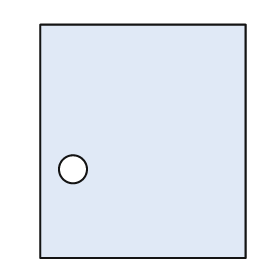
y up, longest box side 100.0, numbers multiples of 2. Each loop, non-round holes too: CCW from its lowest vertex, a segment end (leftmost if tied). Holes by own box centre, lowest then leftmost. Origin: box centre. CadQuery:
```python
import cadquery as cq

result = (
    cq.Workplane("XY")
    .moveTo(-44.0, -50.0)
    .lineTo(44.0, -50.0)
    .lineTo(44.0, 50.0)
    .lineTo(-44.0, 50.0)
    .close()
    .moveTo(-30.0, -12.0)
    .circle(6.0)
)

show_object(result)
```